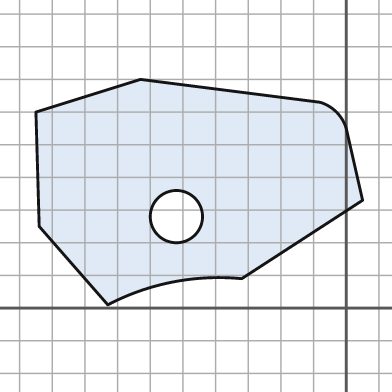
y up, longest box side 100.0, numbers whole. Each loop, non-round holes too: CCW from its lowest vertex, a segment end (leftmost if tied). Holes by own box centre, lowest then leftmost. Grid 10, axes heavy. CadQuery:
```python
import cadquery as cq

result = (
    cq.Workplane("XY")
    .moveTo(-73.0, 1.0)
    .threePointArc((-53.0, 8.0), (-32.0, 9.0))
    .lineTo(5.0, 33.0)
    .lineTo(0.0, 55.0)
    .threePointArc((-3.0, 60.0), (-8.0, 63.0))
    .lineTo(-63.0, 70.0)
    .lineTo(-95.0, 60.0)
    .lineTo(-94.0, 25.0)
    .close()
    .moveTo(-52.0, 28.0)
    .circle(8.0)
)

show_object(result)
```